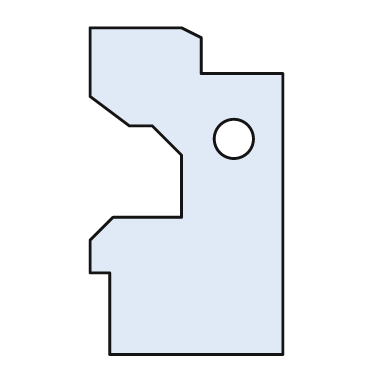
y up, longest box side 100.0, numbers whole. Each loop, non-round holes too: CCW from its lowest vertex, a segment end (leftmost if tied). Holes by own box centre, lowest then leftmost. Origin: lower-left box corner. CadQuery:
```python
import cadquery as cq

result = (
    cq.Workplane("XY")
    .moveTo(6.0, 0.0)
    .lineTo(59.0, 0.0)
    .lineTo(59.0, 86.0)
    .lineTo(34.0, 86.0)
    .lineTo(34.0, 97.0)
    .lineTo(28.0, 100.0)
    .lineTo(0.0, 100.0)
    .lineTo(0.0, 79.0)
    .lineTo(12.0, 70.0)
    .lineTo(19.0, 70.0)
    .lineTo(28.0, 61.0)
    .lineTo(28.0, 42.0)
    .lineTo(7.0, 42.0)
    .lineTo(0.0, 35.0)
    .lineTo(0.0, 25.0)
    .lineTo(6.0, 25.0)
    .close()
    .moveTo(44.0, 66.0)
    .circle(6.0)
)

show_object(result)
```